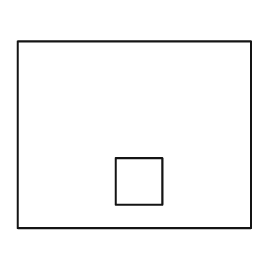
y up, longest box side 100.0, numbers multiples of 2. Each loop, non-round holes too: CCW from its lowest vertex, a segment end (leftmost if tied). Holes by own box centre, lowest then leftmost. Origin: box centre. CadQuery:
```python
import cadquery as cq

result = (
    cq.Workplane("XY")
    .moveTo(-50.0, -40.0)
    .lineTo(50.0, -40.0)
    .lineTo(50.0, 40.0)
    .lineTo(-50.0, 40.0)
    .close()
    .moveTo(-8.0, -30.0)
    .lineTo(12.0, -30.0)
    .lineTo(12.0, -10.0)
    .lineTo(-8.0, -10.0)
    .close()
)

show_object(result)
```